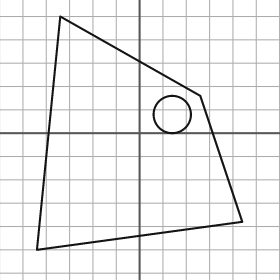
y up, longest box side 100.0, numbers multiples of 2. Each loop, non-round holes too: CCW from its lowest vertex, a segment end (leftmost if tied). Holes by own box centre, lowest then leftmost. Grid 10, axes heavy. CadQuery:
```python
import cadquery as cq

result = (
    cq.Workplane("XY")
    .moveTo(-44.0, -50.0)
    .lineTo(44.0, -38.0)
    .lineTo(26.0, 16.0)
    .lineTo(-34.0, 50.0)
    .close()
    .moveTo(14.0, 8.0)
    .circle(8.0)
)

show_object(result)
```